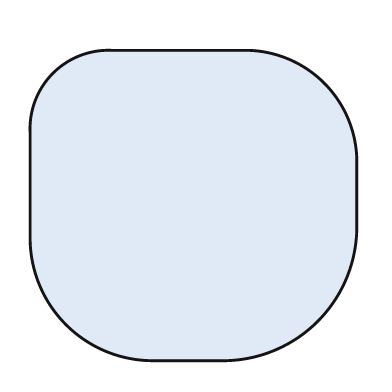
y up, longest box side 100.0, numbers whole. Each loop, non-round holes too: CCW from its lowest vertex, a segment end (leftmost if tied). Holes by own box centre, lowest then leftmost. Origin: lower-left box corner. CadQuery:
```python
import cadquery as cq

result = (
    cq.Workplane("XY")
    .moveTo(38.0, 0.0)
    .lineTo(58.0, 0.0)
    .threePointArc((88.0, 12.0), (100.0, 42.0))
    .lineTo(100.0, 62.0)
    .threePointArc((90.0, 85.0), (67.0, 95.0))
    .lineTo(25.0, 95.0)
    .threePointArc((7.0, 88.0), (0.0, 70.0))
    .lineTo(0.0, 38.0)
    .threePointArc((11.0, 11.0), (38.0, 0.0))
    .close()
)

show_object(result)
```